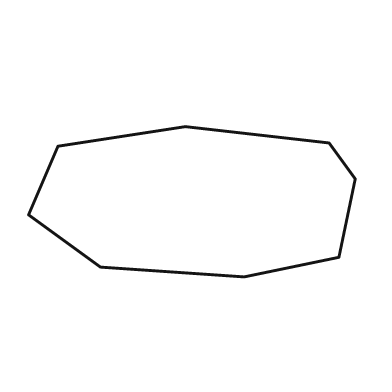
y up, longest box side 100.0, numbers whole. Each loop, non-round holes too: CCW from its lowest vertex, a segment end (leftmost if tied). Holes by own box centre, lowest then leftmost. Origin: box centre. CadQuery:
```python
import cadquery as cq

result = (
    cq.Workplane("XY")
    .moveTo(16.0, -23.0)
    .lineTo(45.0, -17.0)
    .lineTo(50.0, 7.0)
    .lineTo(42.0, 18.0)
    .lineTo(-2.0, 23.0)
    .lineTo(-41.0, 17.0)
    .lineTo(-50.0, -4.0)
    .lineTo(-28.0, -20.0)
    .close()
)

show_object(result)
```